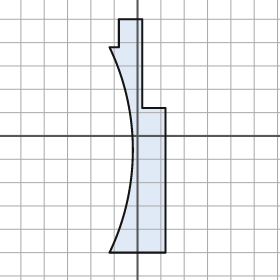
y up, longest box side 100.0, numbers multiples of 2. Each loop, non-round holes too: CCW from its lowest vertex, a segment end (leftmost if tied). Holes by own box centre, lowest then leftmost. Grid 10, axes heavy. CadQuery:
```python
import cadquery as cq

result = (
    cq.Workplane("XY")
    .moveTo(-12.0, -50.0)
    .lineTo(12.0, -50.0)
    .lineTo(12.0, 12.0)
    .lineTo(2.0, 12.0)
    .lineTo(2.0, 50.0)
    .lineTo(-8.0, 50.0)
    .lineTo(-8.0, 38.0)
    .lineTo(-12.0, 38.0)
    .threePointArc((-2.0, -6.0), (-12.0, -50.0))
    .close()
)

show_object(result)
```